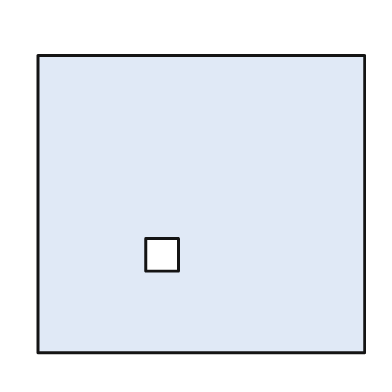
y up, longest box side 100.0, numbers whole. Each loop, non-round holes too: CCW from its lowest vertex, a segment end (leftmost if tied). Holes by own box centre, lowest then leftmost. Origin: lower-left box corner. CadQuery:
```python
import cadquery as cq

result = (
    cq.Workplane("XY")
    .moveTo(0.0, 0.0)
    .lineTo(100.0, 0.0)
    .lineTo(100.0, 91.0)
    .lineTo(0.0, 91.0)
    .close()
    .moveTo(33.0, 25.0)
    .lineTo(43.0, 25.0)
    .lineTo(43.0, 35.0)
    .lineTo(33.0, 35.0)
    .close()
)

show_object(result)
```